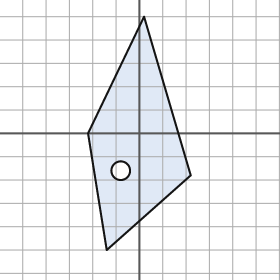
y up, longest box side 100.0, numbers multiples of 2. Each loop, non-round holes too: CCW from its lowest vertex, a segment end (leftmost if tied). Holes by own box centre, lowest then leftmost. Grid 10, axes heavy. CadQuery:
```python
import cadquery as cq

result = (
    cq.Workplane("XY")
    .moveTo(-14.0, -50.0)
    .lineTo(22.0, -18.0)
    .lineTo(2.0, 50.0)
    .lineTo(-22.0, 0.0)
    .close()
    .moveTo(-8.0, -16.0)
    .circle(4.0)
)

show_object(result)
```